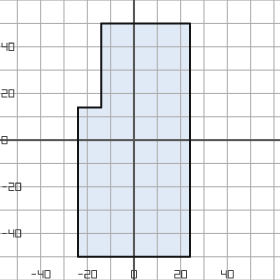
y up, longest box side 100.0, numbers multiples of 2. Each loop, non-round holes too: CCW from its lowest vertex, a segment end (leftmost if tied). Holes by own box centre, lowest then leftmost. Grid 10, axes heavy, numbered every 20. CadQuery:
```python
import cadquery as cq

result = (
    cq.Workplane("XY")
    .moveTo(-24.0, -50.0)
    .lineTo(24.0, -50.0)
    .lineTo(24.0, 50.0)
    .lineTo(-14.0, 50.0)
    .lineTo(-14.0, 14.0)
    .lineTo(-24.0, 14.0)
    .close()
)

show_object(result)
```